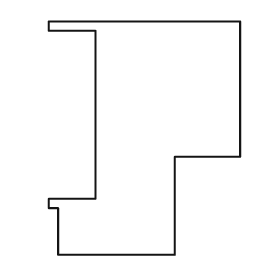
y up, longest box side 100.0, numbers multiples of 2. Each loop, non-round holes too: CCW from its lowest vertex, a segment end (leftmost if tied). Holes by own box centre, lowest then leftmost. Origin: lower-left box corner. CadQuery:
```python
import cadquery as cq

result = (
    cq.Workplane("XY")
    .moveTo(4.0, 0.0)
    .lineTo(54.0, 0.0)
    .lineTo(54.0, 42.0)
    .lineTo(82.0, 42.0)
    .lineTo(82.0, 100.0)
    .lineTo(0.0, 100.0)
    .lineTo(0.0, 96.0)
    .lineTo(20.0, 96.0)
    .lineTo(20.0, 24.0)
    .lineTo(0.0, 24.0)
    .lineTo(0.0, 20.0)
    .lineTo(4.0, 20.0)
    .close()
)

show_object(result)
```